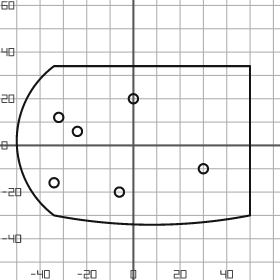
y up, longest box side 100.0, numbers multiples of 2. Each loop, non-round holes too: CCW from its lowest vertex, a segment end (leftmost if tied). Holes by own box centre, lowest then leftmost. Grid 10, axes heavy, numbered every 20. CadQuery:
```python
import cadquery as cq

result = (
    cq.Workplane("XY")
    .moveTo(-34.0, -30.0)
    .threePointArc((8.0, -34.0), (50.0, -30.0))
    .lineTo(50.0, 34.0)
    .lineTo(-34.0, 34.0)
    .threePointArc((-50.0, 2.0), (-34.0, -30.0))
    .close()
    .moveTo(-6.0, -20.0)
    .circle(2.0)
    .moveTo(-34.0, -16.0)
    .circle(2.0)
    .moveTo(30.0, -10.0)
    .circle(2.0)
    .moveTo(-24.0, 6.0)
    .circle(2.0)
    .moveTo(-32.0, 12.0)
    .circle(2.0)
    .moveTo(0.0, 20.0)
    .circle(2.0)
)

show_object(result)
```